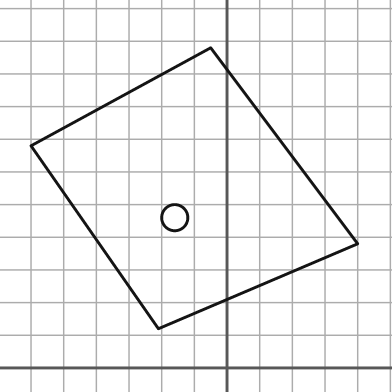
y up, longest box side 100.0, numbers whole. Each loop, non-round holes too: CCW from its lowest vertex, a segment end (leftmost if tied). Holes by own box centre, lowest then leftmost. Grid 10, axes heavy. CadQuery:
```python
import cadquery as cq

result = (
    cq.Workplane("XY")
    .moveTo(-21.0, 12.0)
    .lineTo(40.0, 38.0)
    .lineTo(-5.0, 98.0)
    .lineTo(-60.0, 68.0)
    .close()
    .moveTo(-16.0, 46.0)
    .circle(4.0)
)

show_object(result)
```